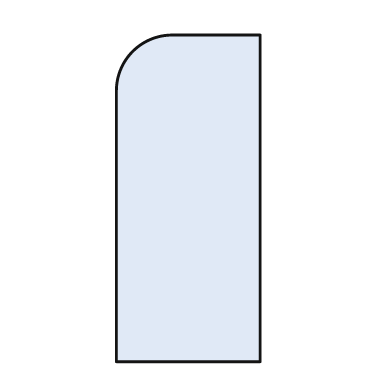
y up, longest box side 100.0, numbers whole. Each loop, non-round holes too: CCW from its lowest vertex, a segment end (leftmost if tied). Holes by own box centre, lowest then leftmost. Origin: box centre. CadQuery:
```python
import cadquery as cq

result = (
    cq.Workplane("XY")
    .moveTo(-22.0, -50.0)
    .lineTo(22.0, -50.0)
    .lineTo(22.0, 50.0)
    .lineTo(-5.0, 50.0)
    .threePointArc((-17.0, 45.0), (-22.0, 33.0))
    .close()
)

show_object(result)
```